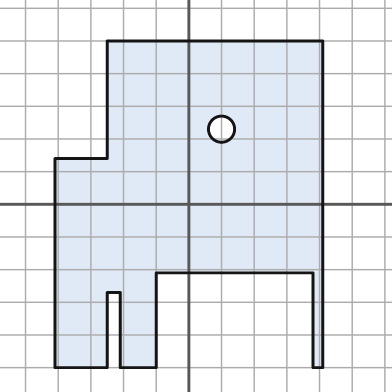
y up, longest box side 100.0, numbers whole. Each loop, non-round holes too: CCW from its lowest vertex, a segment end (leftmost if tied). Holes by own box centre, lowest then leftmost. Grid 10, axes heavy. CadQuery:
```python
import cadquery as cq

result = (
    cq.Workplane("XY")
    .moveTo(-41.0, -50.0)
    .lineTo(-25.0, -50.0)
    .lineTo(-25.0, -27.0)
    .lineTo(-21.0, -27.0)
    .lineTo(-21.0, -50.0)
    .lineTo(-10.0, -50.0)
    .lineTo(-10.0, -21.0)
    .lineTo(38.0, -21.0)
    .lineTo(38.0, -50.0)
    .lineTo(41.0, -50.0)
    .lineTo(41.0, 50.0)
    .lineTo(-25.0, 50.0)
    .lineTo(-25.0, 14.0)
    .lineTo(-41.0, 14.0)
    .close()
    .moveTo(10.0, 23.0)
    .circle(4.0)
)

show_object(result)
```